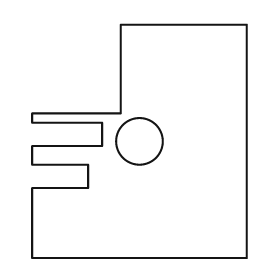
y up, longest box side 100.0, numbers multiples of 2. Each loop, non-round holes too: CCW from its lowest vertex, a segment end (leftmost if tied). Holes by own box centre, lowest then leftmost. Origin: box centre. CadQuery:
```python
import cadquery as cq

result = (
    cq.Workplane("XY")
    .moveTo(-46.0, -50.0)
    .lineTo(46.0, -50.0)
    .lineTo(46.0, 50.0)
    .lineTo(-8.0, 50.0)
    .lineTo(-8.0, 12.0)
    .lineTo(-46.0, 12.0)
    .lineTo(-46.0, 8.0)
    .lineTo(-16.0, 8.0)
    .lineTo(-16.0, -2.0)
    .lineTo(-46.0, -2.0)
    .lineTo(-46.0, -10.0)
    .lineTo(-22.0, -10.0)
    .lineTo(-22.0, -20.0)
    .lineTo(-46.0, -20.0)
    .close()
    .moveTo(0.0, 0.0)
    .circle(10.0)
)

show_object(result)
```